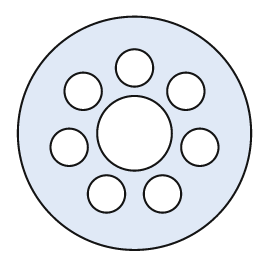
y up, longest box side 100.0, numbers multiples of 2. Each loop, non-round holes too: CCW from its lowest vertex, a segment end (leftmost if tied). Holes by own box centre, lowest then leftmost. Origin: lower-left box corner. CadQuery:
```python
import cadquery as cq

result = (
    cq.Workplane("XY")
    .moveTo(50.0, 50.0)
    .circle(50.0)
    .moveTo(38.0, 24.0)
    .circle(8.0)
    .moveTo(62.0, 24.0)
    .circle(8.0)
    .moveTo(22.0, 44.0)
    .circle(8.0)
    .moveTo(78.0, 44.0)
    .circle(8.0)
    .moveTo(50.0, 50.0)
    .circle(16.0)
    .moveTo(28.0, 68.0)
    .circle(8.0)
    .moveTo(72.0, 68.0)
    .circle(8.0)
    .moveTo(50.0, 78.0)
    .circle(8.0)
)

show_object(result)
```